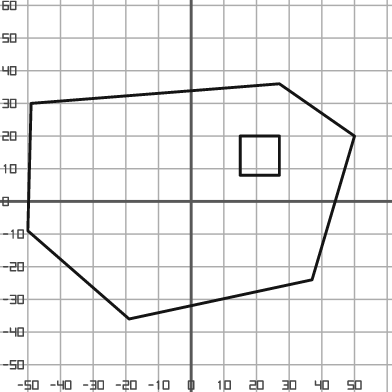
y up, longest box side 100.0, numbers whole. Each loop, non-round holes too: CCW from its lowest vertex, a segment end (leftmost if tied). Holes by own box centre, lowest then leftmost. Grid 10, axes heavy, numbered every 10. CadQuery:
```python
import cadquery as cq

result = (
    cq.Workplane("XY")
    .moveTo(-19.0, -36.0)
    .lineTo(37.0, -24.0)
    .lineTo(50.0, 20.0)
    .lineTo(27.0, 36.0)
    .lineTo(-49.0, 30.0)
    .lineTo(-50.0, -9.0)
    .close()
    .moveTo(15.0, 8.0)
    .lineTo(27.0, 8.0)
    .lineTo(27.0, 20.0)
    .lineTo(15.0, 20.0)
    .close()
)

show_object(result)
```